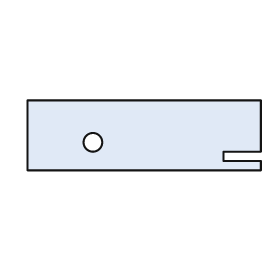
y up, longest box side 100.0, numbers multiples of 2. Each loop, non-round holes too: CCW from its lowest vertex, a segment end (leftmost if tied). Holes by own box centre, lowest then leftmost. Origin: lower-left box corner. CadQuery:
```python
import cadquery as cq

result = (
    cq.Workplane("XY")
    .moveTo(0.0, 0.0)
    .lineTo(100.0, 0.0)
    .lineTo(100.0, 4.0)
    .lineTo(84.0, 4.0)
    .lineTo(84.0, 8.0)
    .lineTo(100.0, 8.0)
    .lineTo(100.0, 30.0)
    .lineTo(0.0, 30.0)
    .close()
    .moveTo(28.0, 12.0)
    .circle(4.0)
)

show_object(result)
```